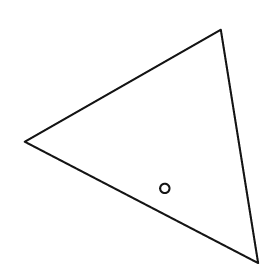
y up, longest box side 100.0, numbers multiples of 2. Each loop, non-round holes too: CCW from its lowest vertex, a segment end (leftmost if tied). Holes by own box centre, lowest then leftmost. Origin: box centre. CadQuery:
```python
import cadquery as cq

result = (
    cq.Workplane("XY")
    .moveTo(50.0, -50.0)
    .lineTo(34.0, 50.0)
    .lineTo(-50.0, 2.0)
    .close()
    .moveTo(10.0, -18.0)
    .circle(2.0)
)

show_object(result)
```